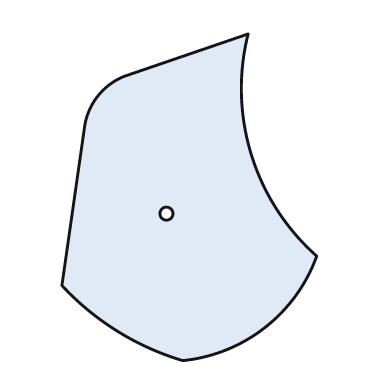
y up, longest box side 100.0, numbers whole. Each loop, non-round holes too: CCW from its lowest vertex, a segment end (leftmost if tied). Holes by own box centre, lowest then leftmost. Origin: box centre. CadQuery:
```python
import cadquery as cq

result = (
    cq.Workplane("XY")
    .moveTo(-2.0, -50.0)
    .threePointArc((23.0, -40.0), (39.0, -18.0))
    .threePointArc((19.0, 13.0), (18.0, 50.0))
    .lineTo(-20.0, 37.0)
    .threePointArc((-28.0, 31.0), (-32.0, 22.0))
    .lineTo(-39.0, -27.0)
    .threePointArc((-22.0, -41.0), (-2.0, -50.0))
    .close()
    .moveTo(-7.0, -5.0)
    .circle(2.0)
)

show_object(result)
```